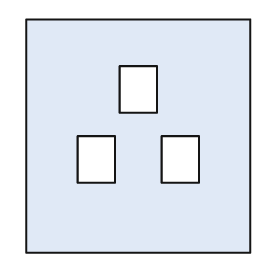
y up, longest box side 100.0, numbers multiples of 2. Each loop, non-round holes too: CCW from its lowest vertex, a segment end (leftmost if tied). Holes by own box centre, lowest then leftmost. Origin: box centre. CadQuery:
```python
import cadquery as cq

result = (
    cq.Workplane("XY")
    .moveTo(-48.0, -50.0)
    .lineTo(48.0, -50.0)
    .lineTo(48.0, 50.0)
    .lineTo(-48.0, 50.0)
    .close()
    .moveTo(-26.0, -20.0)
    .lineTo(-10.0, -20.0)
    .lineTo(-10.0, 0.0)
    .lineTo(-26.0, 0.0)
    .close()
    .moveTo(10.0, -20.0)
    .lineTo(26.0, -20.0)
    .lineTo(26.0, 0.0)
    .lineTo(10.0, 0.0)
    .close()
    .moveTo(-8.0, 10.0)
    .lineTo(8.0, 10.0)
    .lineTo(8.0, 30.0)
    .lineTo(-8.0, 30.0)
    .close()
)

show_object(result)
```